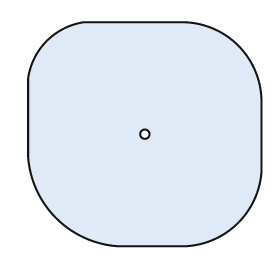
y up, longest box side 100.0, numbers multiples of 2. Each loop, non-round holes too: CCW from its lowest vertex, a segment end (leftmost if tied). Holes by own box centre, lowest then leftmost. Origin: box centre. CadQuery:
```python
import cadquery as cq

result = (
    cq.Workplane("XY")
    .moveTo(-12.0, -48.0)
    .lineTo(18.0, -48.0)
    .threePointArc((40.0, -38.0), (50.0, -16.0))
    .lineTo(50.0, 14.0)
    .threePointArc((40.0, 38.0), (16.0, 48.0))
    .lineTo(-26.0, 48.0)
    .threePointArc((-42.0, 40.0), (-50.0, 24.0))
    .lineTo(-50.0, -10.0)
    .threePointArc((-38.0, -36.0), (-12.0, -48.0))
    .close()
    .moveTo(0.0, 0.0)
    .circle(2.0)
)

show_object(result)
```